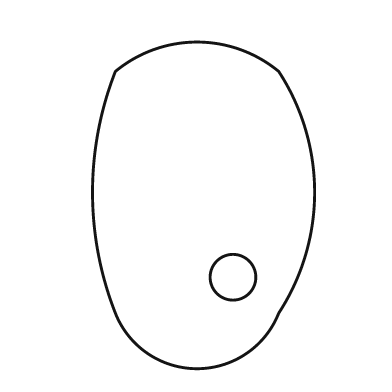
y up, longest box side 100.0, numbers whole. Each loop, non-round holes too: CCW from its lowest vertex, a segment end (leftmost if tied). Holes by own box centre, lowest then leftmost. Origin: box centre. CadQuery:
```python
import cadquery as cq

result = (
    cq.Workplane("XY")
    .moveTo(-27.0, -33.0)
    .threePointArc((-2.0, -50.0), (23.0, -33.0))
    .threePointArc((34.0, 4.0), (23.0, 41.0))
    .threePointArc((-2.0, 50.0), (-27.0, 41.0))
    .threePointArc((-34.0, 4.0), (-27.0, -33.0))
    .close()
    .moveTo(9.0, -22.0)
    .circle(7.0)
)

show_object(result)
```